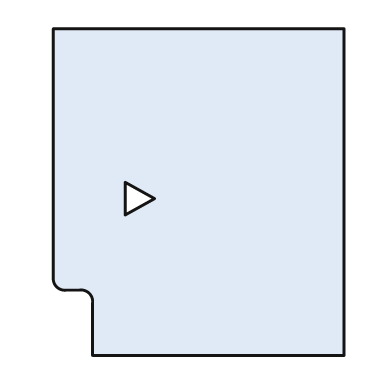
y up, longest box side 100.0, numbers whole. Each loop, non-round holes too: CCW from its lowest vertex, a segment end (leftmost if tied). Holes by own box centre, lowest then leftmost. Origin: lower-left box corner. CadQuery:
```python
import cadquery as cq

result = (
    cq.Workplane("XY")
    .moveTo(12.0, 0.0)
    .lineTo(89.0, 0.0)
    .lineTo(89.0, 100.0)
    .lineTo(0.0, 100.0)
    .lineTo(0.0, 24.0)
    .threePointArc((1.0, 21.0), (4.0, 20.0))
    .lineTo(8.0, 20.0)
    .threePointArc((11.0, 19.0), (12.0, 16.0))
    .close()
    .moveTo(22.0, 43.0)
    .lineTo(31.0, 48.0)
    .lineTo(22.0, 53.0)
    .close()
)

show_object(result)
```